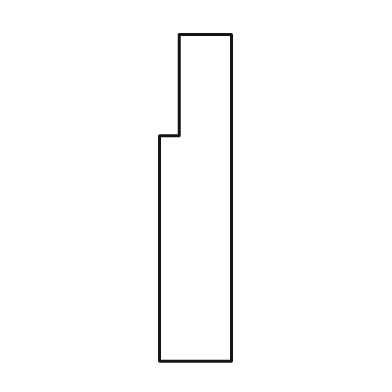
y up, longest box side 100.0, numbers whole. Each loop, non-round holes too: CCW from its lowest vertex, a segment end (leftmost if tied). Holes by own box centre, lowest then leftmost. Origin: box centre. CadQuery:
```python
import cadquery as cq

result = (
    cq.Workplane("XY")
    .moveTo(-11.0, -50.0)
    .lineTo(11.0, -50.0)
    .lineTo(11.0, 50.0)
    .lineTo(-5.0, 50.0)
    .lineTo(-5.0, 19.0)
    .lineTo(-11.0, 19.0)
    .close()
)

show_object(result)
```